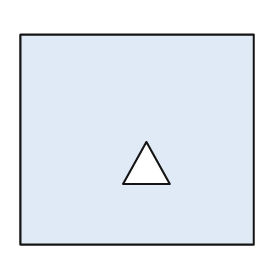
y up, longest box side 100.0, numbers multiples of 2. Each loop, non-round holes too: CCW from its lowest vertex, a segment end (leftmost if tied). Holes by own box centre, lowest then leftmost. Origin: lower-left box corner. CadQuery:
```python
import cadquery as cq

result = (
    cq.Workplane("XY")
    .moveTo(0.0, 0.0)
    .lineTo(100.0, 0.0)
    .lineTo(100.0, 90.0)
    .lineTo(0.0, 90.0)
    .close()
    .moveTo(44.0, 26.0)
    .lineTo(64.0, 26.0)
    .lineTo(54.0, 44.0)
    .close()
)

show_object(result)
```